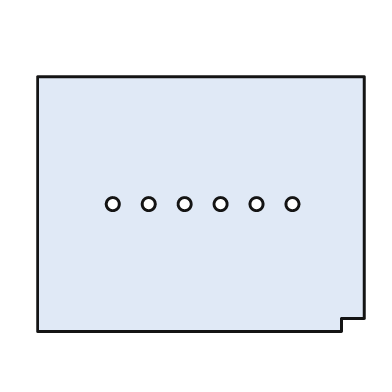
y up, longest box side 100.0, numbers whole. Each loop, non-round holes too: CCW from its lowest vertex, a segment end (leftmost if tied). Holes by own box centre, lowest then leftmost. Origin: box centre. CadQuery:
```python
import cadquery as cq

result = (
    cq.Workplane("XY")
    .moveTo(-50.0, -39.0)
    .lineTo(43.0, -39.0)
    .lineTo(43.0, -35.0)
    .lineTo(50.0, -35.0)
    .lineTo(50.0, 39.0)
    .lineTo(-50.0, 39.0)
    .close()
    .moveTo(-27.0, 0.0)
    .circle(2.0)
    .moveTo(-16.0, 0.0)
    .circle(2.0)
    .moveTo(-5.0, 0.0)
    .circle(2.0)
    .moveTo(6.0, 0.0)
    .circle(2.0)
    .moveTo(17.0, 0.0)
    .circle(2.0)
    .moveTo(28.0, 0.0)
    .circle(2.0)
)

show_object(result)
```